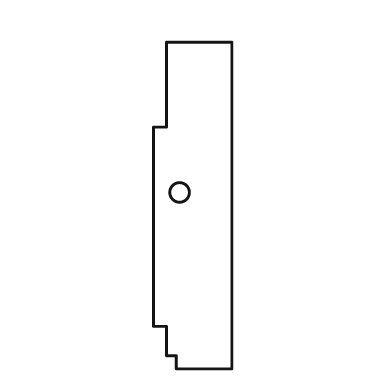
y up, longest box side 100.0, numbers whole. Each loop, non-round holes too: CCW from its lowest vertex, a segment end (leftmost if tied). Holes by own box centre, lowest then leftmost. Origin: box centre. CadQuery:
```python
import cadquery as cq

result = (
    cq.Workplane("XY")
    .moveTo(-5.0, -50.0)
    .lineTo(12.0, -50.0)
    .lineTo(12.0, 50.0)
    .lineTo(-8.0, 50.0)
    .lineTo(-8.0, 24.0)
    .lineTo(-12.0, 24.0)
    .lineTo(-12.0, -37.0)
    .lineTo(-8.0, -37.0)
    .lineTo(-8.0, -46.0)
    .lineTo(-5.0, -46.0)
    .close()
    .moveTo(-4.0, 4.0)
    .circle(3.0)
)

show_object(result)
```